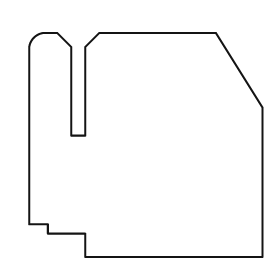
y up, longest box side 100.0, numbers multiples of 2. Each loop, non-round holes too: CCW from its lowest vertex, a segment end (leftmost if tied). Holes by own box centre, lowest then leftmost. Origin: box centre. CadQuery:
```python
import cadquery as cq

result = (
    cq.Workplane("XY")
    .moveTo(-26.0, -48.0)
    .lineTo(50.0, -48.0)
    .lineTo(50.0, 16.0)
    .lineTo(30.0, 48.0)
    .lineTo(-20.0, 48.0)
    .lineTo(-26.0, 42.0)
    .lineTo(-26.0, 4.0)
    .lineTo(-32.0, 4.0)
    .lineTo(-32.0, 42.0)
    .lineTo(-38.0, 48.0)
    .lineTo(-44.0, 48.0)
    .threePointArc((-48.0, 46.0), (-50.0, 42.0))
    .lineTo(-50.0, -34.0)
    .lineTo(-42.0, -34.0)
    .lineTo(-42.0, -38.0)
    .lineTo(-26.0, -38.0)
    .close()
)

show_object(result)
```